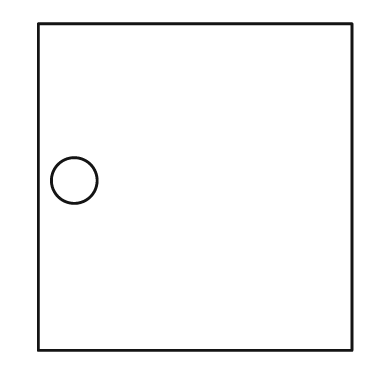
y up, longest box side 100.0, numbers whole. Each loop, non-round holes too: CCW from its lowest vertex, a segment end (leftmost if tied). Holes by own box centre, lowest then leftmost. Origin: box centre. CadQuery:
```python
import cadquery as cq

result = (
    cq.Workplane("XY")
    .moveTo(-48.0, -50.0)
    .lineTo(48.0, -50.0)
    .lineTo(48.0, 50.0)
    .lineTo(-48.0, 50.0)
    .close()
    .moveTo(-37.0, 2.0)
    .circle(7.0)
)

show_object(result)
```